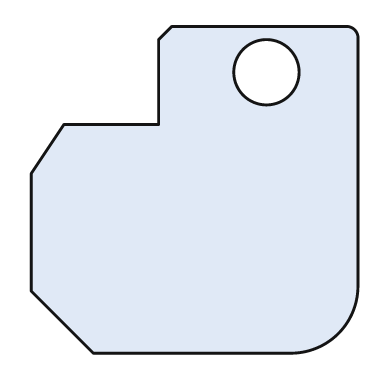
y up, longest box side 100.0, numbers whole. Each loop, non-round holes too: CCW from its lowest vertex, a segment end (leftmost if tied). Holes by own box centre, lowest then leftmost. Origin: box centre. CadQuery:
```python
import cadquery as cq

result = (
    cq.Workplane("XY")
    .moveTo(-31.0, -50.0)
    .lineTo(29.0, -50.0)
    .threePointArc((44.0, -44.0), (50.0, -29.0))
    .lineTo(50.0, 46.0)
    .threePointArc((49.0, 49.0), (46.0, 50.0))
    .lineTo(-7.0, 50.0)
    .lineTo(-11.0, 46.0)
    .lineTo(-11.0, 20.0)
    .lineTo(-40.0, 20.0)
    .lineTo(-50.0, 5.0)
    .lineTo(-50.0, -31.0)
    .close()
    .moveTo(22.0, 36.0)
    .circle(10.0)
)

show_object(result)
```